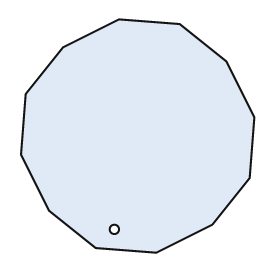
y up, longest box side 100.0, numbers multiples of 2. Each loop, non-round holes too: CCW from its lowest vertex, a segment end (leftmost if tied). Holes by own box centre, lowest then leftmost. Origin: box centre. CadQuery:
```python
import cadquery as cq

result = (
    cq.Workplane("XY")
    .moveTo(8.0, -50.0)
    .lineTo(32.0, -38.0)
    .lineTo(48.0, -18.0)
    .lineTo(50.0, 8.0)
    .lineTo(38.0, 32.0)
    .lineTo(18.0, 48.0)
    .lineTo(-8.0, 50.0)
    .lineTo(-32.0, 38.0)
    .lineTo(-48.0, 18.0)
    .lineTo(-50.0, -8.0)
    .lineTo(-38.0, -32.0)
    .lineTo(-18.0, -48.0)
    .close()
    .moveTo(-10.0, -40.0)
    .circle(2.0)
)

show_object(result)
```